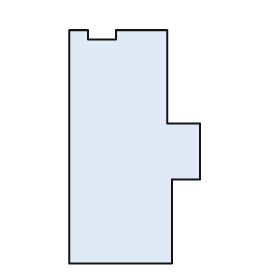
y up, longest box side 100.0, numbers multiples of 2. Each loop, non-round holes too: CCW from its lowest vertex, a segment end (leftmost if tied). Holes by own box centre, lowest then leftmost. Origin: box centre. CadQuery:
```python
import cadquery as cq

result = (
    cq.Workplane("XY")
    .moveTo(-28.0, -50.0)
    .lineTo(16.0, -50.0)
    .lineTo(16.0, -14.0)
    .lineTo(28.0, -14.0)
    .lineTo(28.0, 10.0)
    .lineTo(14.0, 10.0)
    .lineTo(14.0, 50.0)
    .lineTo(-8.0, 50.0)
    .lineTo(-8.0, 46.0)
    .lineTo(-20.0, 46.0)
    .lineTo(-20.0, 50.0)
    .lineTo(-28.0, 50.0)
    .close()
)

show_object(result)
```